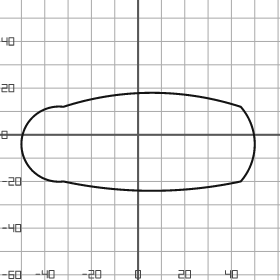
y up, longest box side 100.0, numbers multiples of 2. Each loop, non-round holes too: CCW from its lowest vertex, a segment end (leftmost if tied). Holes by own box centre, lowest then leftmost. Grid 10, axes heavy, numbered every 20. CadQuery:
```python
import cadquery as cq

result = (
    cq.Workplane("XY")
    .moveTo(-32.0, -20.0)
    .threePointArc((6.0, -24.0), (44.0, -20.0))
    .threePointArc((50.0, -4.0), (44.0, 12.0))
    .threePointArc((6.0, 18.0), (-32.0, 12.0))
    .threePointArc((-50.0, -4.0), (-32.0, -20.0))
    .close()
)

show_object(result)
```